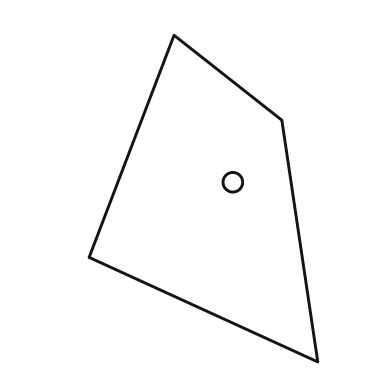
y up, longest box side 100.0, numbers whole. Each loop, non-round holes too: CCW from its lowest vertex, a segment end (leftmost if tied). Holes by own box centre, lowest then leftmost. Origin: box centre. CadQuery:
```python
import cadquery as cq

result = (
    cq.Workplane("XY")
    .moveTo(35.0, -50.0)
    .lineTo(24.0, 24.0)
    .lineTo(-9.0, 50.0)
    .lineTo(-35.0, -18.0)
    .close()
    .moveTo(9.0, 5.0)
    .circle(3.0)
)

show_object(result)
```